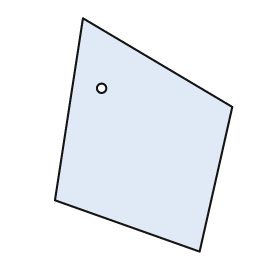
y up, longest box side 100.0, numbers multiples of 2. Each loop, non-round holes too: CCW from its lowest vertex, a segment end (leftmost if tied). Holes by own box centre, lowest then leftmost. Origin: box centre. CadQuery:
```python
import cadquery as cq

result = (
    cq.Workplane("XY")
    .moveTo(24.0, -50.0)
    .lineTo(38.0, 12.0)
    .lineTo(-26.0, 50.0)
    .lineTo(-38.0, -28.0)
    .close()
    .moveTo(-18.0, 20.0)
    .circle(2.0)
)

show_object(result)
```